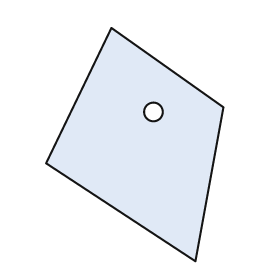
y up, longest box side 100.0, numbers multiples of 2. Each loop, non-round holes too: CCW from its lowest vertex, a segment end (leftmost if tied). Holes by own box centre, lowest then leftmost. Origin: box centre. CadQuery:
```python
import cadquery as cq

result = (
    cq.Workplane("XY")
    .moveTo(26.0, -50.0)
    .lineTo(38.0, 16.0)
    .lineTo(-10.0, 50.0)
    .lineTo(-38.0, -8.0)
    .close()
    .moveTo(8.0, 14.0)
    .circle(4.0)
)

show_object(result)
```